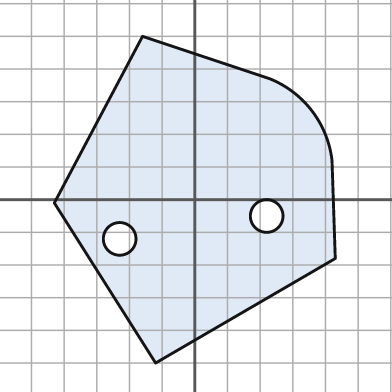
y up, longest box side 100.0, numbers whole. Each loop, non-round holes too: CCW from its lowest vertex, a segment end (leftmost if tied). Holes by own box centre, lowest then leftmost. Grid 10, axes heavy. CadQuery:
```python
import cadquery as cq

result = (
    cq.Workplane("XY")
    .moveTo(-12.0, -50.0)
    .lineTo(43.0, -18.0)
    .lineTo(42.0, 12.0)
    .threePointArc((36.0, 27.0), (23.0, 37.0))
    .lineTo(-16.0, 50.0)
    .lineTo(-43.0, -1.0)
    .close()
    .moveTo(-23.0, -12.0)
    .circle(5.0)
    .moveTo(22.0, -5.0)
    .circle(5.0)
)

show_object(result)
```